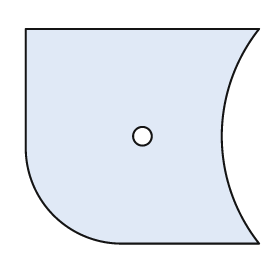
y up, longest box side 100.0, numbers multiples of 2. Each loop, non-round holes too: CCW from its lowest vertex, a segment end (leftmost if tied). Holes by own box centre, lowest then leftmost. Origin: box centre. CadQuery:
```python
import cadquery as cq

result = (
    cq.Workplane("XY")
    .moveTo(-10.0, -46.0)
    .lineTo(50.0, -46.0)
    .threePointArc((34.0, 0.0), (50.0, 46.0))
    .lineTo(-50.0, 46.0)
    .lineTo(-50.0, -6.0)
    .threePointArc((-38.0, -34.0), (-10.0, -46.0))
    .close()
    .moveTo(0.0, 0.0)
    .circle(4.0)
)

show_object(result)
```